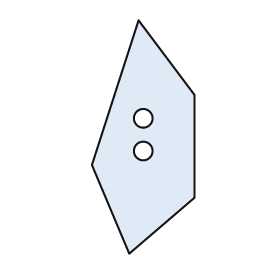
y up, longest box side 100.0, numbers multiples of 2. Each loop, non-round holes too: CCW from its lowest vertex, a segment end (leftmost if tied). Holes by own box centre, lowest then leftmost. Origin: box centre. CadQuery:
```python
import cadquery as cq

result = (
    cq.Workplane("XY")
    .moveTo(-6.0, -50.0)
    .lineTo(22.0, -26.0)
    .lineTo(22.0, 18.0)
    .lineTo(-2.0, 50.0)
    .lineTo(-22.0, -12.0)
    .close()
    .moveTo(0.0, -6.0)
    .circle(4.0)
    .moveTo(0.0, 8.0)
    .circle(4.0)
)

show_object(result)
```